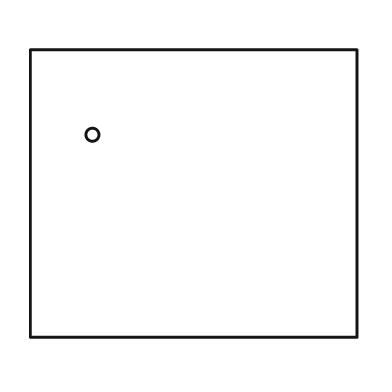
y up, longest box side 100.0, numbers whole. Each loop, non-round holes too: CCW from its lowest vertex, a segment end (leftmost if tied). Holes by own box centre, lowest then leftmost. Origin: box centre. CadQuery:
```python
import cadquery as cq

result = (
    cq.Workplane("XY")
    .moveTo(-50.0, -44.0)
    .lineTo(50.0, -44.0)
    .lineTo(50.0, 44.0)
    .lineTo(-50.0, 44.0)
    .close()
    .moveTo(-31.0, 18.0)
    .circle(2.0)
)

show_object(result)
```